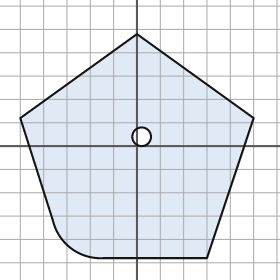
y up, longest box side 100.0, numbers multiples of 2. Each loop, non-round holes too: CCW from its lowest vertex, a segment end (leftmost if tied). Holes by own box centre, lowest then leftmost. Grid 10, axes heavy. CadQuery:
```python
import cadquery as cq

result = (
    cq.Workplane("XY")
    .moveTo(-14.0, -48.0)
    .lineTo(30.0, -48.0)
    .lineTo(50.0, 12.0)
    .lineTo(0.0, 48.0)
    .lineTo(-50.0, 12.0)
    .lineTo(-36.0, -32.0)
    .threePointArc((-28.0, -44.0), (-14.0, -48.0))
    .close()
    .moveTo(2.0, 4.0)
    .circle(4.0)
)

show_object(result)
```